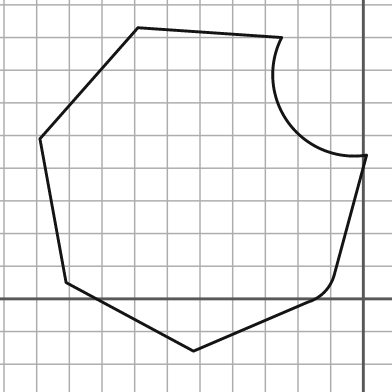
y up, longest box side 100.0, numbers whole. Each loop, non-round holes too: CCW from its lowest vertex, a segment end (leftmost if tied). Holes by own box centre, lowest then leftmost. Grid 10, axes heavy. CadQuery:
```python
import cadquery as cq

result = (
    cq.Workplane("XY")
    .moveTo(-52.0, -16.0)
    .lineTo(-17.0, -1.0)
    .threePointArc((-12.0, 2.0), (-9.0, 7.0))
    .lineTo(1.0, 44.0)
    .threePointArc((-23.0, 54.0), (-25.0, 80.0))
    .lineTo(-69.0, 83.0)
    .lineTo(-99.0, 49.0)
    .lineTo(-91.0, 5.0)
    .close()
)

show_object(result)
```